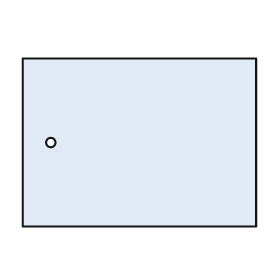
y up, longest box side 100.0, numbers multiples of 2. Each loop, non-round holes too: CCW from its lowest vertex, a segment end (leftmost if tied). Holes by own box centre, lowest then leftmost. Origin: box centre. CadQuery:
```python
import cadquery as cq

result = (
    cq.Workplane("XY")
    .moveTo(-50.0, -36.0)
    .lineTo(50.0, -36.0)
    .lineTo(50.0, 36.0)
    .lineTo(-50.0, 36.0)
    .close()
    .moveTo(-38.0, 0.0)
    .circle(2.0)
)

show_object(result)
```